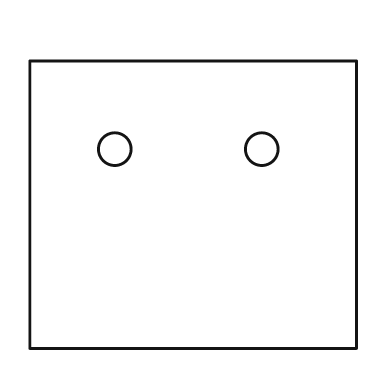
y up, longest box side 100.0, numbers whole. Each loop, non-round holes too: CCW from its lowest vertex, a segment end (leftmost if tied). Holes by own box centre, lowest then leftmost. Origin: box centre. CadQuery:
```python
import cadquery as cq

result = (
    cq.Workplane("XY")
    .moveTo(-50.0, -44.0)
    .lineTo(50.0, -44.0)
    .lineTo(50.0, 44.0)
    .lineTo(-50.0, 44.0)
    .close()
    .moveTo(-24.0, 17.0)
    .circle(5.0)
    .moveTo(21.0, 17.0)
    .circle(5.0)
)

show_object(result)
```